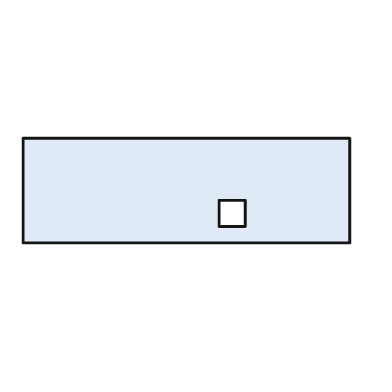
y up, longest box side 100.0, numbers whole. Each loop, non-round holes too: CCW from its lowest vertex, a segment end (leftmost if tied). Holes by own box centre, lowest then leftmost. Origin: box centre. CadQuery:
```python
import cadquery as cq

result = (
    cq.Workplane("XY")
    .moveTo(-50.0, -16.0)
    .lineTo(50.0, -16.0)
    .lineTo(50.0, 16.0)
    .lineTo(-50.0, 16.0)
    .close()
    .moveTo(10.0, -11.0)
    .lineTo(18.0, -11.0)
    .lineTo(18.0, -3.0)
    .lineTo(10.0, -3.0)
    .close()
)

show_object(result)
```